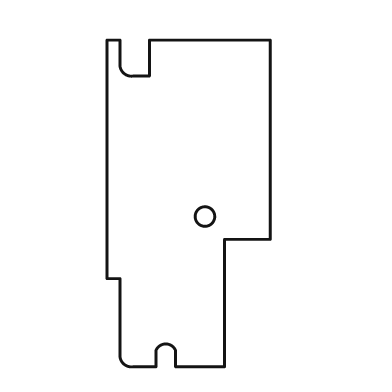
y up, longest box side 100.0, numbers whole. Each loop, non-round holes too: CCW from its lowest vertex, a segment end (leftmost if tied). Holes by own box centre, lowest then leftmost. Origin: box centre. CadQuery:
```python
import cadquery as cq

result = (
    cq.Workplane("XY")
    .moveTo(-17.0, -50.0)
    .lineTo(-10.0, -50.0)
    .lineTo(-10.0, -45.0)
    .threePointArc((-7.0, -43.0), (-4.0, -45.0))
    .lineTo(-4.0, -50.0)
    .lineTo(11.0, -50.0)
    .lineTo(11.0, -11.0)
    .lineTo(25.0, -11.0)
    .lineTo(25.0, 50.0)
    .lineTo(-12.0, 50.0)
    .lineTo(-12.0, 39.0)
    .lineTo(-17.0, 39.0)
    .threePointArc((-20.0, 40.0), (-21.0, 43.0))
    .lineTo(-21.0, 50.0)
    .lineTo(-25.0, 50.0)
    .lineTo(-25.0, -23.0)
    .lineTo(-21.0, -23.0)
    .lineTo(-21.0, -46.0)
    .threePointArc((-20.0, -49.0), (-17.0, -50.0))
    .close()
    .moveTo(5.0, -4.0)
    .circle(3.0)
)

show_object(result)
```